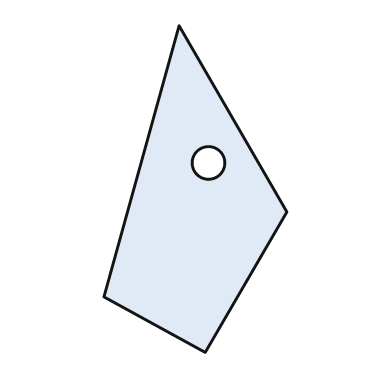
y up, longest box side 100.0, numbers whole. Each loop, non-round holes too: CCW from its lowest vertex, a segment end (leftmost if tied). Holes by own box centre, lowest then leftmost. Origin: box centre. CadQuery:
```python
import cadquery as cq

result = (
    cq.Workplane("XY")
    .moveTo(3.0, -50.0)
    .lineTo(28.0, -7.0)
    .lineTo(-5.0, 50.0)
    .lineTo(-28.0, -33.0)
    .close()
    .moveTo(4.0, 8.0)
    .circle(5.0)
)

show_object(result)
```